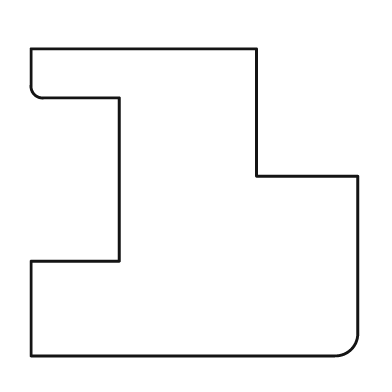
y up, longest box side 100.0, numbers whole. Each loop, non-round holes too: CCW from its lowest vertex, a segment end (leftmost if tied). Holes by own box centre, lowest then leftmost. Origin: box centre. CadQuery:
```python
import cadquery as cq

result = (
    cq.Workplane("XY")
    .moveTo(-50.0, -47.0)
    .lineTo(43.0, -47.0)
    .threePointArc((48.0, -45.0), (50.0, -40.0))
    .lineTo(50.0, 8.0)
    .lineTo(19.0, 8.0)
    .lineTo(19.0, 47.0)
    .lineTo(-50.0, 47.0)
    .lineTo(-50.0, 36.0)
    .threePointArc((-49.0, 33.0), (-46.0, 32.0))
    .lineTo(-23.0, 32.0)
    .lineTo(-23.0, -18.0)
    .lineTo(-50.0, -18.0)
    .close()
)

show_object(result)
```